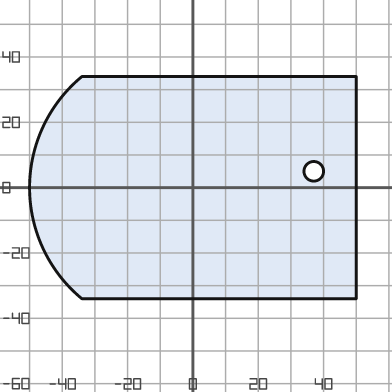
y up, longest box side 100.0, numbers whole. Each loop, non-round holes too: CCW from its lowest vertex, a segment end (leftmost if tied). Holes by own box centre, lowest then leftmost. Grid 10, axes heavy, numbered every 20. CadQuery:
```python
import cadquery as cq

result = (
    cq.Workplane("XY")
    .moveTo(-34.0, -34.0)
    .lineTo(50.0, -34.0)
    .lineTo(50.0, 34.0)
    .lineTo(-34.0, 34.0)
    .threePointArc((-50.0, 0.0), (-34.0, -34.0))
    .close()
    .moveTo(37.0, 5.0)
    .circle(3.0)
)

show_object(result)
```